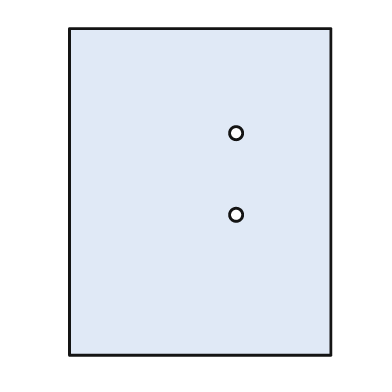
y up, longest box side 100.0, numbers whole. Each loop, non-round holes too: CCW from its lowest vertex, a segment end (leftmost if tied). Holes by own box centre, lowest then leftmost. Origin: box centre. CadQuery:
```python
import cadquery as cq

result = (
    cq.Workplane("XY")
    .moveTo(-40.0, -50.0)
    .lineTo(40.0, -50.0)
    .lineTo(40.0, 50.0)
    .lineTo(-40.0, 50.0)
    .close()
    .moveTo(11.0, -7.0)
    .circle(2.0)
    .moveTo(11.0, 18.0)
    .circle(2.0)
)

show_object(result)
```